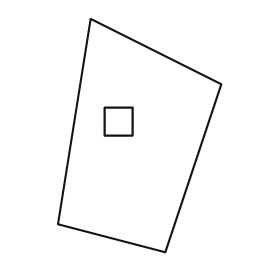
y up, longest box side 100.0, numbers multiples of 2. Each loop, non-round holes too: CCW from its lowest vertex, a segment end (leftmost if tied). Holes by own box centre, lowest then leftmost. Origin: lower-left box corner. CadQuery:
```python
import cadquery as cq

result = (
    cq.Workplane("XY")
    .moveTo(46.0, 0.0)
    .lineTo(70.0, 72.0)
    .lineTo(14.0, 100.0)
    .lineTo(0.0, 12.0)
    .close()
    .moveTo(20.0, 50.0)
    .lineTo(32.0, 50.0)
    .lineTo(32.0, 62.0)
    .lineTo(20.0, 62.0)
    .close()
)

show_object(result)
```